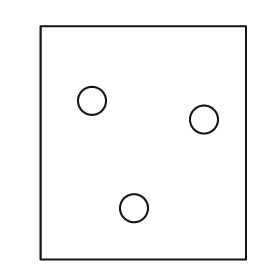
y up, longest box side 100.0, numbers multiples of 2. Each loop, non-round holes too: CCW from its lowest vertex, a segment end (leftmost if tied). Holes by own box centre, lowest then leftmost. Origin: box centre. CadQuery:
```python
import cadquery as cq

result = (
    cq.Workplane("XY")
    .moveTo(-44.0, -50.0)
    .lineTo(44.0, -50.0)
    .lineTo(44.0, 50.0)
    .lineTo(-44.0, 50.0)
    .close()
    .moveTo(-4.0, -28.0)
    .circle(6.0)
    .moveTo(26.0, 10.0)
    .circle(6.0)
    .moveTo(-22.0, 18.0)
    .circle(6.0)
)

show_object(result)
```